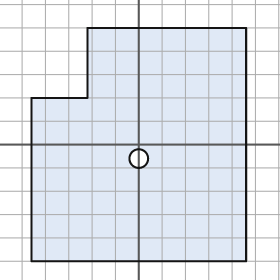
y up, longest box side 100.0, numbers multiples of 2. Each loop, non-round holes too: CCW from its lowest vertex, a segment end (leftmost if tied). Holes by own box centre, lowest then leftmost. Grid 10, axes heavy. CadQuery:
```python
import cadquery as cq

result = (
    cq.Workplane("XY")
    .moveTo(-46.0, -50.0)
    .lineTo(46.0, -50.0)
    .lineTo(46.0, 50.0)
    .lineTo(-22.0, 50.0)
    .lineTo(-22.0, 20.0)
    .lineTo(-46.0, 20.0)
    .close()
    .moveTo(0.0, -6.0)
    .circle(4.0)
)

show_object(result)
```